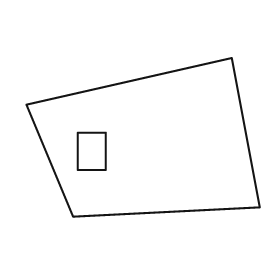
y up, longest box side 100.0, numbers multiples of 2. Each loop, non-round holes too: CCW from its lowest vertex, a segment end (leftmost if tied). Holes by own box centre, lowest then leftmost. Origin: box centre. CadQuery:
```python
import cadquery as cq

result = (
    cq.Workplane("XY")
    .moveTo(-30.0, -34.0)
    .lineTo(50.0, -30.0)
    .lineTo(38.0, 34.0)
    .lineTo(-50.0, 14.0)
    .close()
    .moveTo(-28.0, -14.0)
    .lineTo(-16.0, -14.0)
    .lineTo(-16.0, 2.0)
    .lineTo(-28.0, 2.0)
    .close()
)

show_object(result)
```